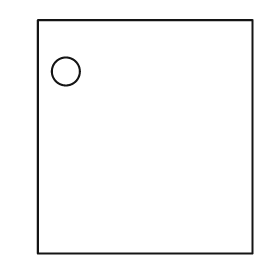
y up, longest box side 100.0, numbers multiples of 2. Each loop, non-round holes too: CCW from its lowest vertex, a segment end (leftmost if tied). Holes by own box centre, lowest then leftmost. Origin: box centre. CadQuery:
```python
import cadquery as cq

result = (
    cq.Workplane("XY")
    .moveTo(-46.0, -50.0)
    .lineTo(46.0, -50.0)
    .lineTo(46.0, 50.0)
    .lineTo(-46.0, 50.0)
    .close()
    .moveTo(-34.0, 28.0)
    .circle(6.0)
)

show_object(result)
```